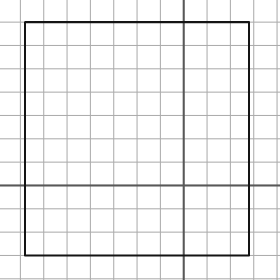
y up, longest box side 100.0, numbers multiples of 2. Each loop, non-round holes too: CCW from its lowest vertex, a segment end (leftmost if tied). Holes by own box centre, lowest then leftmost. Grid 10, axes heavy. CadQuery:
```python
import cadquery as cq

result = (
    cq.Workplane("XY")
    .moveTo(-68.0, -30.0)
    .lineTo(28.0, -30.0)
    .lineTo(28.0, 70.0)
    .lineTo(-68.0, 70.0)
    .close()
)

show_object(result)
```